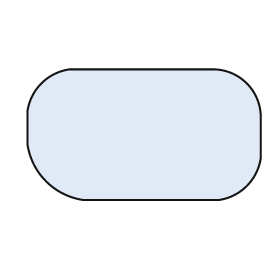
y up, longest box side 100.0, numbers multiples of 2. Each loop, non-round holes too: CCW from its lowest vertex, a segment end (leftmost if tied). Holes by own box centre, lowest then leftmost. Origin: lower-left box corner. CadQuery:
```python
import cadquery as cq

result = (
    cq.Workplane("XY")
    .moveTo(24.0, 0.0)
    .lineTo(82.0, 0.0)
    .threePointArc((94.0, 6.0), (100.0, 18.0))
    .lineTo(100.0, 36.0)
    .threePointArc((94.0, 50.0), (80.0, 56.0))
    .lineTo(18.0, 56.0)
    .threePointArc((6.0, 50.0), (0.0, 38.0))
    .lineTo(0.0, 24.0)
    .threePointArc((8.0, 8.0), (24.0, 0.0))
    .close()
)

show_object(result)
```